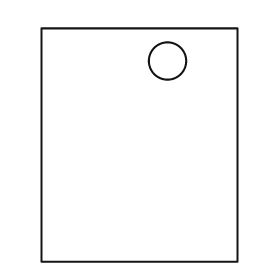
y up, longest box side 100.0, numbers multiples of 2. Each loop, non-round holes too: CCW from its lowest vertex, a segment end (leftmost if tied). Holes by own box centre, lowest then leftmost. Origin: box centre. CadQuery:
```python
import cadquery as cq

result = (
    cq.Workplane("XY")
    .moveTo(-42.0, -50.0)
    .lineTo(42.0, -50.0)
    .lineTo(42.0, 50.0)
    .lineTo(-42.0, 50.0)
    .close()
    .moveTo(12.0, 36.0)
    .circle(8.0)
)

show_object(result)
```